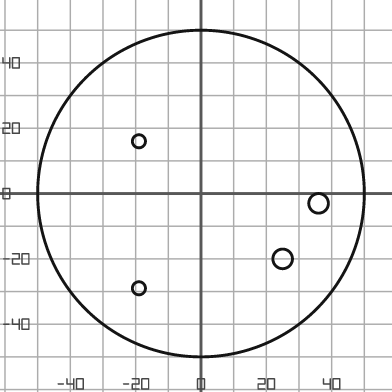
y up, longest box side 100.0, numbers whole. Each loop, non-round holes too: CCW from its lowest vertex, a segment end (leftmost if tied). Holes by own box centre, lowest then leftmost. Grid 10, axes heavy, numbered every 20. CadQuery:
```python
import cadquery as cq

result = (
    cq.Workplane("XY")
    .moveTo(0.0, 0.0)
    .circle(50.0)
    .moveTo(-19.0, -29.0)
    .circle(2.0)
    .moveTo(25.0, -20.0)
    .circle(3.0)
    .moveTo(36.0, -3.0)
    .circle(3.0)
    .moveTo(-19.0, 16.0)
    .circle(2.0)
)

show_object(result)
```